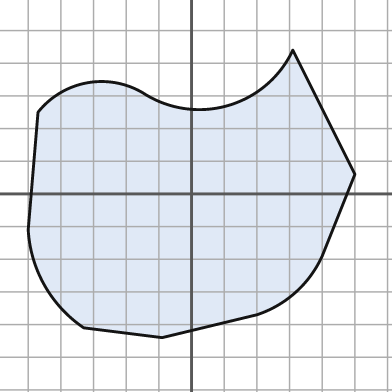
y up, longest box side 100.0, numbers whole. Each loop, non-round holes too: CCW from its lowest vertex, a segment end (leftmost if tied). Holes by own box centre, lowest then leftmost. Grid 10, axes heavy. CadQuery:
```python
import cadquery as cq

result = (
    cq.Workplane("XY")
    .moveTo(-9.0, -44.0)
    .lineTo(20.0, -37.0)
    .threePointArc((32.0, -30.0), (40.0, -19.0))
    .lineTo(50.0, 6.0)
    .lineTo(31.0, 44.0)
    .threePointArc((11.0, 27.0), (-15.0, 31.0))
    .threePointArc((-32.0, 34.0), (-47.0, 25.0))
    .lineTo(-50.0, -11.0)
    .threePointArc((-45.0, -28.0), (-33.0, -41.0))
    .close()
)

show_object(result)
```